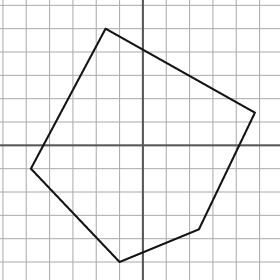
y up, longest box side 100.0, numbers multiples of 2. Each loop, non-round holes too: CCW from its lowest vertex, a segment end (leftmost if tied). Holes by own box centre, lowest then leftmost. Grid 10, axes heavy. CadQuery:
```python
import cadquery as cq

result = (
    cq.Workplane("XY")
    .moveTo(-10.0, -50.0)
    .lineTo(24.0, -36.0)
    .lineTo(48.0, 14.0)
    .lineTo(-16.0, 50.0)
    .lineTo(-48.0, -10.0)
    .close()
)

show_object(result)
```